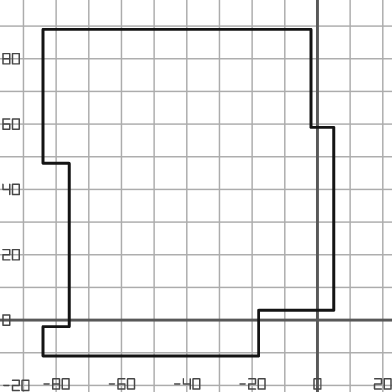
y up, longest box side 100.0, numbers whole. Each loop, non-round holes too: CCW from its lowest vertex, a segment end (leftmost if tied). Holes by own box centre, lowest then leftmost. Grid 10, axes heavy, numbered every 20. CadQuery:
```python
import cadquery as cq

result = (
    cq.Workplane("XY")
    .moveTo(-84.0, -11.0)
    .lineTo(-18.0, -11.0)
    .lineTo(-18.0, 3.0)
    .lineTo(5.0, 3.0)
    .lineTo(5.0, 59.0)
    .lineTo(-2.0, 59.0)
    .lineTo(-2.0, 89.0)
    .lineTo(-84.0, 89.0)
    .lineTo(-84.0, 48.0)
    .lineTo(-76.0, 48.0)
    .lineTo(-76.0, -2.0)
    .lineTo(-84.0, -2.0)
    .close()
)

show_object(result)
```